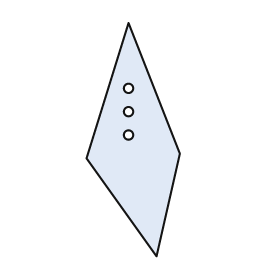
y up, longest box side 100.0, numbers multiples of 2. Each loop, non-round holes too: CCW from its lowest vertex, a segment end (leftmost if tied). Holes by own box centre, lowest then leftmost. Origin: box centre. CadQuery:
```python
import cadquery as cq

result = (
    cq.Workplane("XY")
    .moveTo(10.0, -50.0)
    .lineTo(20.0, -6.0)
    .lineTo(-2.0, 50.0)
    .lineTo(-20.0, -8.0)
    .close()
    .moveTo(-2.0, 2.0)
    .circle(2.0)
    .moveTo(-2.0, 12.0)
    .circle(2.0)
    .moveTo(-2.0, 22.0)
    .circle(2.0)
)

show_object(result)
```